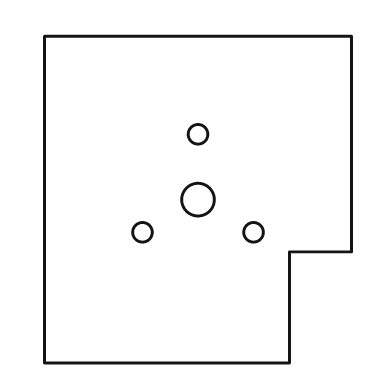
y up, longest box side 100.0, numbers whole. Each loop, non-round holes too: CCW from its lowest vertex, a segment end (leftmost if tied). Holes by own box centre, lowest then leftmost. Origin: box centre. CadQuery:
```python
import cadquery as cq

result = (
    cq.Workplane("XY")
    .moveTo(-47.0, -50.0)
    .lineTo(28.0, -50.0)
    .lineTo(28.0, -16.0)
    .lineTo(47.0, -16.0)
    .lineTo(47.0, 50.0)
    .lineTo(-47.0, 50.0)
    .close()
    .moveTo(-17.0, -10.0)
    .circle(3.0)
    .moveTo(17.0, -10.0)
    .circle(3.0)
    .moveTo(0.0, 0.0)
    .circle(5.0)
    .moveTo(0.0, 20.0)
    .circle(3.0)
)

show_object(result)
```